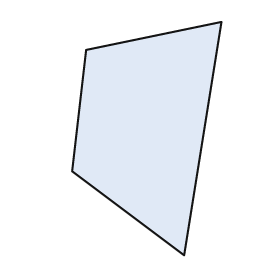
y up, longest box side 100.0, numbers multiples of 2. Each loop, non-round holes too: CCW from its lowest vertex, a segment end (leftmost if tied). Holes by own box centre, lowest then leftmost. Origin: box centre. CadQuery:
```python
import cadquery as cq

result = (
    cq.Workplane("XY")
    .moveTo(16.0, -50.0)
    .lineTo(32.0, 50.0)
    .lineTo(-26.0, 38.0)
    .lineTo(-32.0, -14.0)
    .close()
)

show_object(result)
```